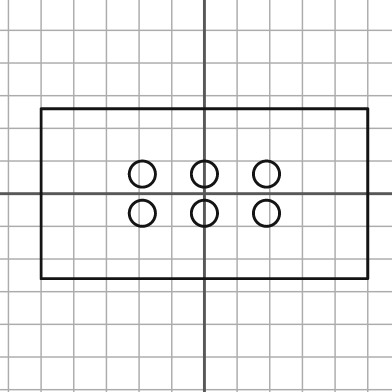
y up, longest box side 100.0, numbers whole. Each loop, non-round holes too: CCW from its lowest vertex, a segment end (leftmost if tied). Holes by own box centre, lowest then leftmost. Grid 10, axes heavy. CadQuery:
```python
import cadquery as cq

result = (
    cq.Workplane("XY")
    .moveTo(-50.0, -26.0)
    .lineTo(50.0, -26.0)
    .lineTo(50.0, 26.0)
    .lineTo(-50.0, 26.0)
    .close()
    .moveTo(-19.0, -6.0)
    .circle(4.0)
    .moveTo(0.0, -6.0)
    .circle(4.0)
    .moveTo(19.0, -6.0)
    .circle(4.0)
    .moveTo(-19.0, 6.0)
    .circle(4.0)
    .moveTo(0.0, 6.0)
    .circle(4.0)
    .moveTo(19.0, 6.0)
    .circle(4.0)
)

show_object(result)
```